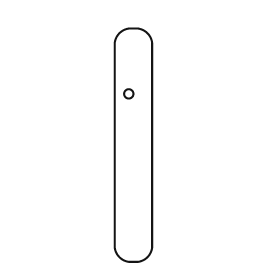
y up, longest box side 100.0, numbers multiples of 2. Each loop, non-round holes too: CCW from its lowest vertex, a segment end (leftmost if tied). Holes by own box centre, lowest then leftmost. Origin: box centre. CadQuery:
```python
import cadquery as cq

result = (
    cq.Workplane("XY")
    .moveTo(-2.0, -50.0)
    .lineTo(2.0, -50.0)
    .threePointArc((6.0, -48.0), (8.0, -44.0))
    .lineTo(8.0, 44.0)
    .threePointArc((6.0, 48.0), (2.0, 50.0))
    .lineTo(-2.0, 50.0)
    .threePointArc((-6.0, 48.0), (-8.0, 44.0))
    .lineTo(-8.0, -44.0)
    .threePointArc((-6.0, -48.0), (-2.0, -50.0))
    .close()
    .moveTo(-2.0, 22.0)
    .circle(2.0)
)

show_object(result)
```